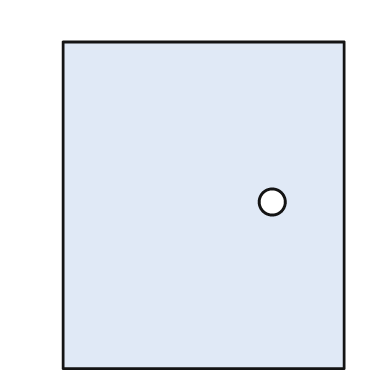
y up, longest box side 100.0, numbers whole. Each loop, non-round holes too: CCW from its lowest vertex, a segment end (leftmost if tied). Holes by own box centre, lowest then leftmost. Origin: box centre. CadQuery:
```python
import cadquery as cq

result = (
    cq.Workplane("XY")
    .moveTo(-43.0, -50.0)
    .lineTo(43.0, -50.0)
    .lineTo(43.0, 50.0)
    .lineTo(-43.0, 50.0)
    .close()
    .moveTo(21.0, 1.0)
    .circle(4.0)
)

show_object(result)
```